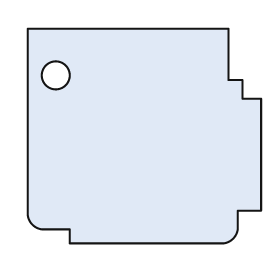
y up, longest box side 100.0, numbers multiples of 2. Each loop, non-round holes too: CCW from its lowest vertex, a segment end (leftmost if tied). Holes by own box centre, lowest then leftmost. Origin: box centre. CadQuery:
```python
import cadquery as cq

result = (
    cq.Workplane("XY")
    .moveTo(-32.0, -46.0)
    .lineTo(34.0, -46.0)
    .threePointArc((38.0, -44.0), (40.0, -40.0))
    .lineTo(40.0, -32.0)
    .lineTo(50.0, -32.0)
    .lineTo(50.0, 16.0)
    .lineTo(42.0, 16.0)
    .lineTo(42.0, 24.0)
    .lineTo(36.0, 24.0)
    .lineTo(36.0, 46.0)
    .lineTo(-50.0, 46.0)
    .lineTo(-50.0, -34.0)
    .threePointArc((-48.0, -38.0), (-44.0, -40.0))
    .lineTo(-32.0, -40.0)
    .close()
    .moveTo(-38.0, 26.0)
    .circle(6.0)
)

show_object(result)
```